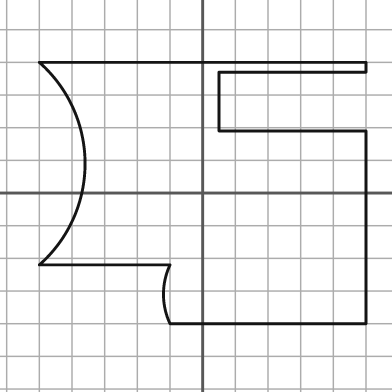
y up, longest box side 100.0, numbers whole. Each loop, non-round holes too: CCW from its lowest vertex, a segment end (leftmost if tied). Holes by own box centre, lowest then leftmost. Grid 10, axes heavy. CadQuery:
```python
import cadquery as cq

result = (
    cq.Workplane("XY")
    .moveTo(-10.0, -40.0)
    .lineTo(50.0, -40.0)
    .lineTo(50.0, 19.0)
    .lineTo(5.0, 19.0)
    .lineTo(5.0, 37.0)
    .lineTo(50.0, 37.0)
    .lineTo(50.0, 40.0)
    .lineTo(-50.0, 40.0)
    .threePointArc((-36.0, 9.0), (-50.0, -22.0))
    .lineTo(-10.0, -22.0)
    .threePointArc((-12.0, -31.0), (-10.0, -40.0))
    .close()
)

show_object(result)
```